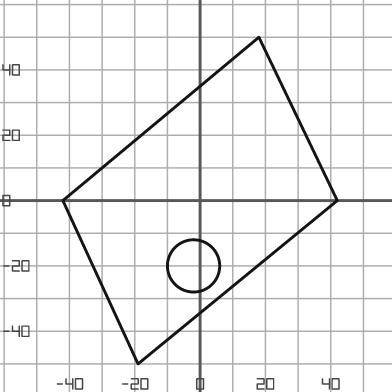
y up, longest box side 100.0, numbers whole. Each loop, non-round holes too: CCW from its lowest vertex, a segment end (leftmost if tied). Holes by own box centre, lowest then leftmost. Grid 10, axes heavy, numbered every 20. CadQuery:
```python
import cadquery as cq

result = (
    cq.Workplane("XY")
    .moveTo(-19.0, -50.0)
    .lineTo(42.0, 0.0)
    .lineTo(18.0, 50.0)
    .lineTo(-42.0, 0.0)
    .close()
    .moveTo(-2.0, -20.0)
    .circle(8.0)
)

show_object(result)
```